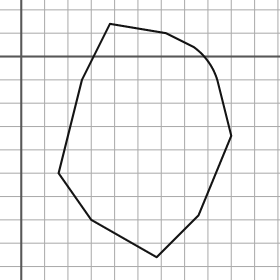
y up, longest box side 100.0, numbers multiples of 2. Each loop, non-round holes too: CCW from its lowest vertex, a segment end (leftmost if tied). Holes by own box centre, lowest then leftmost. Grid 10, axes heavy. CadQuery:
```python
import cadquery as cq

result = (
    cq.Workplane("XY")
    .moveTo(58.0, -86.0)
    .lineTo(76.0, -68.0)
    .lineTo(90.0, -34.0)
    .lineTo(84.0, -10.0)
    .threePointArc((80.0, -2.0), (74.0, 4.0))
    .lineTo(62.0, 10.0)
    .lineTo(38.0, 14.0)
    .lineTo(26.0, -10.0)
    .lineTo(16.0, -50.0)
    .lineTo(30.0, -70.0)
    .close()
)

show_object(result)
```